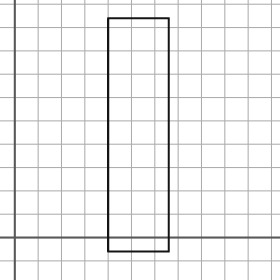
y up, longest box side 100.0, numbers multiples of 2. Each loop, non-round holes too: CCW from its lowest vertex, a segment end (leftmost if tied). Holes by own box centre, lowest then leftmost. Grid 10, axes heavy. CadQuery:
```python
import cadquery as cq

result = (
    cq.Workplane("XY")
    .moveTo(40.0, -6.0)
    .lineTo(66.0, -6.0)
    .lineTo(66.0, 94.0)
    .lineTo(40.0, 94.0)
    .close()
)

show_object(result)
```